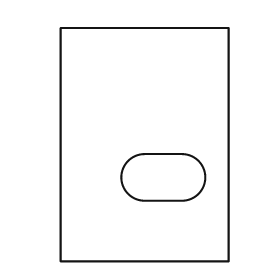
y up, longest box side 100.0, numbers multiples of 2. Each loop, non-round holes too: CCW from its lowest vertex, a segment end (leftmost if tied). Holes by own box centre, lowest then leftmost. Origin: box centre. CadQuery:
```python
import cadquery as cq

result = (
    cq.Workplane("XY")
    .moveTo(-36.0, -50.0)
    .lineTo(36.0, -50.0)
    .lineTo(36.0, 50.0)
    .lineTo(-36.0, 50.0)
    .close()
    .moveTo(0.0, -24.0)
    .lineTo(16.0, -24.0)
    .threePointArc((26.0, -14.0), (16.0, -4.0))
    .lineTo(0.0, -4.0)
    .threePointArc((-10.0, -14.0), (0.0, -24.0))
    .close()
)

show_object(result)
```